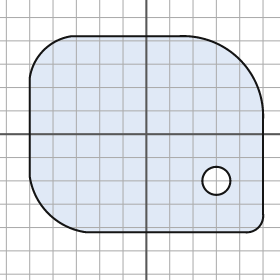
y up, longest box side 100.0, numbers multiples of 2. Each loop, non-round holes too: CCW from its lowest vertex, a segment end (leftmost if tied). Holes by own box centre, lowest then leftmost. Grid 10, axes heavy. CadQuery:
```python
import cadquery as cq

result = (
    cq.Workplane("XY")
    .moveTo(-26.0, -42.0)
    .lineTo(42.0, -42.0)
    .threePointArc((48.0, -40.0), (50.0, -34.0))
    .lineTo(50.0, 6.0)
    .threePointArc((40.0, 32.0), (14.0, 42.0))
    .lineTo(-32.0, 42.0)
    .threePointArc((-44.0, 36.0), (-50.0, 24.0))
    .lineTo(-50.0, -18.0)
    .threePointArc((-42.0, -34.0), (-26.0, -42.0))
    .close()
    .moveTo(30.0, -20.0)
    .circle(6.0)
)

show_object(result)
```